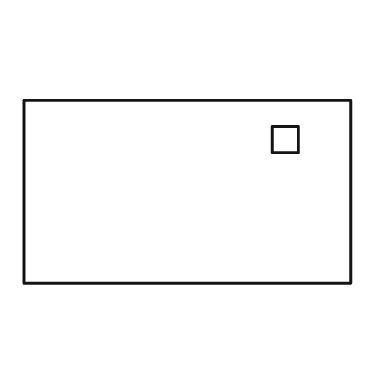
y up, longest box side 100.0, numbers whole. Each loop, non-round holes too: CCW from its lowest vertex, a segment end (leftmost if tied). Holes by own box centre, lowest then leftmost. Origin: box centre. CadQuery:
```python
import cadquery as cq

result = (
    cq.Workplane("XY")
    .moveTo(-50.0, -28.0)
    .lineTo(50.0, -28.0)
    .lineTo(50.0, 28.0)
    .lineTo(-50.0, 28.0)
    .close()
    .moveTo(26.0, 12.0)
    .lineTo(34.0, 12.0)
    .lineTo(34.0, 20.0)
    .lineTo(26.0, 20.0)
    .close()
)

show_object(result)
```